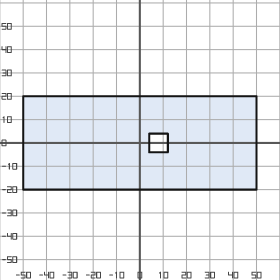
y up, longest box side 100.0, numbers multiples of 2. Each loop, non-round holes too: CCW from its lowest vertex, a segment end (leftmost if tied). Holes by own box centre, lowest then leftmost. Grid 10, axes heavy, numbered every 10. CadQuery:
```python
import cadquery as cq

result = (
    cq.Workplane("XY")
    .moveTo(-50.0, -20.0)
    .lineTo(50.0, -20.0)
    .lineTo(50.0, 20.0)
    .lineTo(-50.0, 20.0)
    .close()
    .moveTo(4.0, -4.0)
    .lineTo(12.0, -4.0)
    .lineTo(12.0, 4.0)
    .lineTo(4.0, 4.0)
    .close()
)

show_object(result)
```